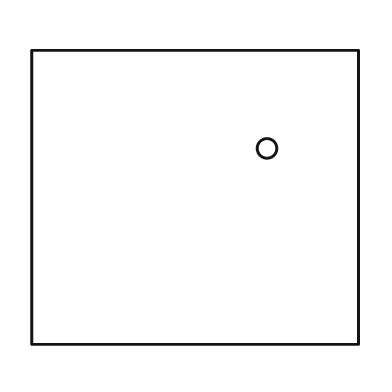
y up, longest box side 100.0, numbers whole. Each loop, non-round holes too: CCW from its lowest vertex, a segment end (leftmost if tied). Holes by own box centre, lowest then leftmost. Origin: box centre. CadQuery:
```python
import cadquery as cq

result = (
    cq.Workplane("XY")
    .moveTo(-50.0, -45.0)
    .lineTo(50.0, -45.0)
    .lineTo(50.0, 45.0)
    .lineTo(-50.0, 45.0)
    .close()
    .moveTo(22.0, 15.0)
    .circle(3.0)
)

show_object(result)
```